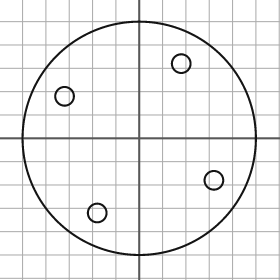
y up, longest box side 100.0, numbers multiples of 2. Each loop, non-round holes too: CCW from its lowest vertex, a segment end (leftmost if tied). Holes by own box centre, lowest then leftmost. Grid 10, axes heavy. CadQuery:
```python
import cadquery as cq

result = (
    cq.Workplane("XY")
    .moveTo(0.0, 0.0)
    .circle(50.0)
    .moveTo(-18.0, -32.0)
    .circle(4.0)
    .moveTo(32.0, -18.0)
    .circle(4.0)
    .moveTo(-32.0, 18.0)
    .circle(4.0)
    .moveTo(18.0, 32.0)
    .circle(4.0)
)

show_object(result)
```